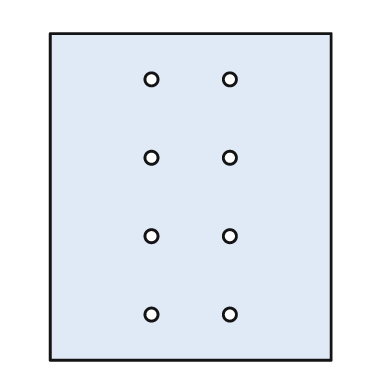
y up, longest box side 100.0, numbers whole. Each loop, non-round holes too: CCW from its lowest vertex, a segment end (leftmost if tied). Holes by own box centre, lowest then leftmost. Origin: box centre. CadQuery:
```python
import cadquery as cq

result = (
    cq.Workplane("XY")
    .moveTo(-43.0, -50.0)
    .lineTo(43.0, -50.0)
    .lineTo(43.0, 50.0)
    .lineTo(-43.0, 50.0)
    .close()
    .moveTo(-12.0, -36.0)
    .circle(2.0)
    .moveTo(12.0, -36.0)
    .circle(2.0)
    .moveTo(-12.0, -12.0)
    .circle(2.0)
    .moveTo(12.0, -12.0)
    .circle(2.0)
    .moveTo(-12.0, 12.0)
    .circle(2.0)
    .moveTo(12.0, 12.0)
    .circle(2.0)
    .moveTo(-12.0, 36.0)
    .circle(2.0)
    .moveTo(12.0, 36.0)
    .circle(2.0)
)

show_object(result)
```